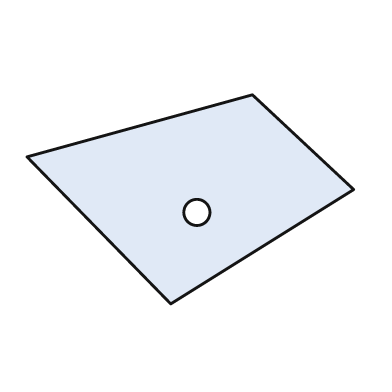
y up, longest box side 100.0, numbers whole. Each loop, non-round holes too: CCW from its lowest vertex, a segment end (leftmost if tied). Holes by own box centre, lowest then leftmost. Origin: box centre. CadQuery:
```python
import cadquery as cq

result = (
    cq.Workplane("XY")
    .moveTo(-6.0, -32.0)
    .lineTo(50.0, 3.0)
    .lineTo(19.0, 32.0)
    .lineTo(-50.0, 13.0)
    .close()
    .moveTo(2.0, -4.0)
    .circle(4.0)
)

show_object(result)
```